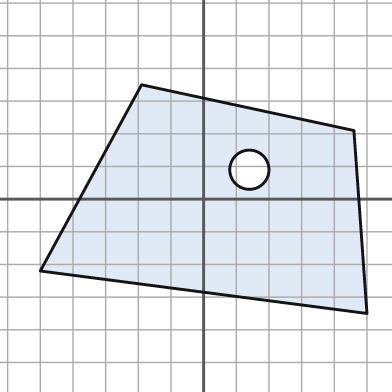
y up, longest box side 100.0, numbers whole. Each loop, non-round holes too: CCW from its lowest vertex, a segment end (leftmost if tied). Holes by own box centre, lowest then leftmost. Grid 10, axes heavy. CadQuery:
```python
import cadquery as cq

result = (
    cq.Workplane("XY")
    .moveTo(50.0, -35.0)
    .lineTo(46.0, 21.0)
    .lineTo(-19.0, 35.0)
    .lineTo(-50.0, -22.0)
    .close()
    .moveTo(14.0, 9.0)
    .circle(6.0)
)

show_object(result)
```